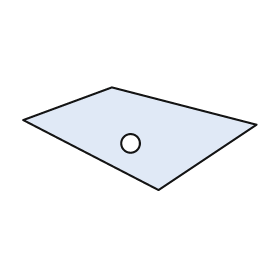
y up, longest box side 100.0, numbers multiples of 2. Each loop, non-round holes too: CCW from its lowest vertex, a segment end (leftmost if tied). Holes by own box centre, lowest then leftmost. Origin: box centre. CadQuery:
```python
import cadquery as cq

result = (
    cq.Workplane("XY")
    .moveTo(8.0, -22.0)
    .lineTo(50.0, 6.0)
    .lineTo(-12.0, 22.0)
    .lineTo(-50.0, 8.0)
    .close()
    .moveTo(-4.0, -2.0)
    .circle(4.0)
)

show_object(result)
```